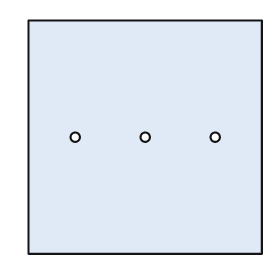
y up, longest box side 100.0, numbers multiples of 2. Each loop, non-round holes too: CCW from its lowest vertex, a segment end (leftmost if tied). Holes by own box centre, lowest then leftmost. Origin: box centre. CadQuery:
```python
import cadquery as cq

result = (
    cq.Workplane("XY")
    .moveTo(-50.0, -50.0)
    .lineTo(50.0, -50.0)
    .lineTo(50.0, 50.0)
    .lineTo(-50.0, 50.0)
    .close()
    .moveTo(-30.0, 0.0)
    .circle(2.0)
    .moveTo(0.0, 0.0)
    .circle(2.0)
    .moveTo(30.0, 0.0)
    .circle(2.0)
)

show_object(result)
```